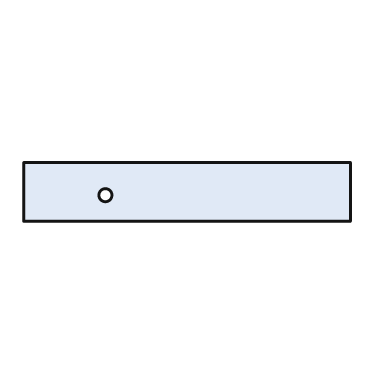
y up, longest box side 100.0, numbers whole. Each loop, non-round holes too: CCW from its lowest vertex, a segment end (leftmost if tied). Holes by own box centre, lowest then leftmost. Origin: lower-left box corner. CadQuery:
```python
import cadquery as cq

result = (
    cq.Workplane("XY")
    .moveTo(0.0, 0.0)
    .lineTo(100.0, 0.0)
    .lineTo(100.0, 18.0)
    .lineTo(0.0, 18.0)
    .close()
    .moveTo(25.0, 8.0)
    .circle(2.0)
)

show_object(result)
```